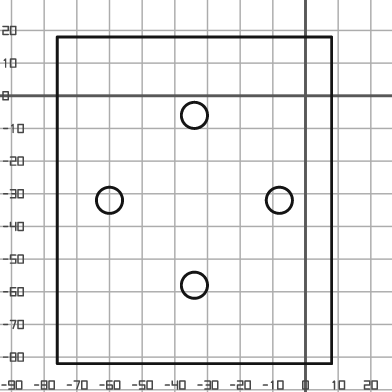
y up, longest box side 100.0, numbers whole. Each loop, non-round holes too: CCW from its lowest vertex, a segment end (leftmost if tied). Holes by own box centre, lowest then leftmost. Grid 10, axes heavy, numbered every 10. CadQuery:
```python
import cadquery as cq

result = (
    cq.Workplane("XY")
    .moveTo(-76.0, -82.0)
    .lineTo(8.0, -82.0)
    .lineTo(8.0, 18.0)
    .lineTo(-76.0, 18.0)
    .close()
    .moveTo(-34.0, -58.0)
    .circle(4.0)
    .moveTo(-60.0, -32.0)
    .circle(4.0)
    .moveTo(-8.0, -32.0)
    .circle(4.0)
    .moveTo(-34.0, -6.0)
    .circle(4.0)
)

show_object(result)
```